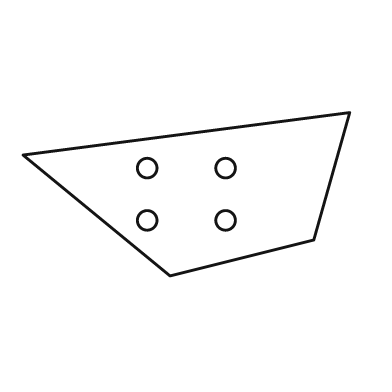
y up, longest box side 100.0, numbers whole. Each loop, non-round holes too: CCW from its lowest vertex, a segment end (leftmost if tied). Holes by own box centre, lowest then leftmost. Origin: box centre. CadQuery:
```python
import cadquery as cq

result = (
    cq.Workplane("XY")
    .moveTo(-5.0, -25.0)
    .lineTo(39.0, -14.0)
    .lineTo(50.0, 25.0)
    .lineTo(-50.0, 12.0)
    .close()
    .moveTo(-12.0, -8.0)
    .circle(3.0)
    .moveTo(12.0, -8.0)
    .circle(3.0)
    .moveTo(-12.0, 8.0)
    .circle(3.0)
    .moveTo(12.0, 8.0)
    .circle(3.0)
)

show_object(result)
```